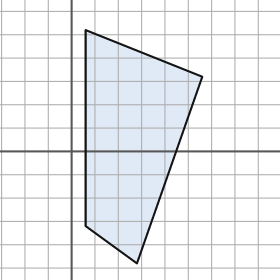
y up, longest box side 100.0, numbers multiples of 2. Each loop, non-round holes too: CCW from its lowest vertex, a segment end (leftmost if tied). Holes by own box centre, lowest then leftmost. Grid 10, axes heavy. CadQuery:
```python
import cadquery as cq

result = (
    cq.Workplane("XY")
    .moveTo(28.0, -48.0)
    .lineTo(56.0, 32.0)
    .lineTo(6.0, 52.0)
    .lineTo(6.0, -32.0)
    .close()
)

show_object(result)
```